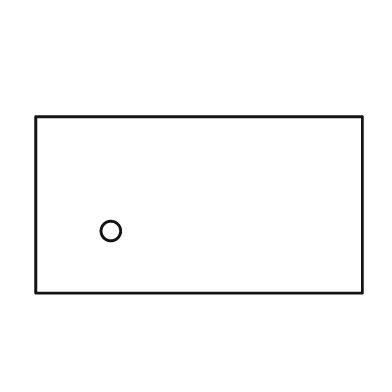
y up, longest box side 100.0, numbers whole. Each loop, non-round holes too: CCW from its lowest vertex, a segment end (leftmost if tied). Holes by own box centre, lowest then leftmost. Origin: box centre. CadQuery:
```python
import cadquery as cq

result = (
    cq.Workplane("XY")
    .moveTo(-50.0, -27.0)
    .lineTo(50.0, -27.0)
    .lineTo(50.0, 27.0)
    .lineTo(-50.0, 27.0)
    .close()
    .moveTo(-27.0, -8.0)
    .circle(3.0)
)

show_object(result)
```